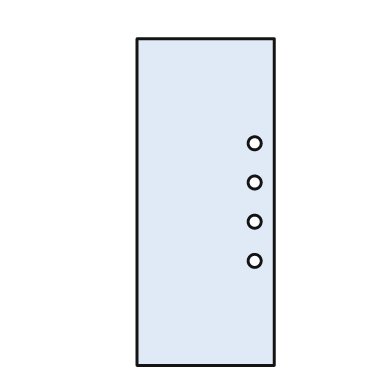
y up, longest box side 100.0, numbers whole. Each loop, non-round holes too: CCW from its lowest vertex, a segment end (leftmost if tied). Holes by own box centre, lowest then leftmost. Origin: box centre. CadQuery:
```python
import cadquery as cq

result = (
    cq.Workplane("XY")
    .moveTo(-21.0, -50.0)
    .lineTo(21.0, -50.0)
    .lineTo(21.0, 50.0)
    .lineTo(-21.0, 50.0)
    .close()
    .moveTo(15.0, -18.0)
    .circle(2.0)
    .moveTo(15.0, -6.0)
    .circle(2.0)
    .moveTo(15.0, 6.0)
    .circle(2.0)
    .moveTo(15.0, 18.0)
    .circle(2.0)
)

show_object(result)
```